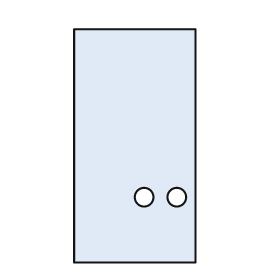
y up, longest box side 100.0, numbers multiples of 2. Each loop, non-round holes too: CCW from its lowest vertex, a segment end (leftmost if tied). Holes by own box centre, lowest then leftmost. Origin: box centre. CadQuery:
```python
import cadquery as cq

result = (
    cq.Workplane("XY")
    .moveTo(-26.0, -50.0)
    .lineTo(26.0, -50.0)
    .lineTo(26.0, 50.0)
    .lineTo(-26.0, 50.0)
    .close()
    .moveTo(4.0, -22.0)
    .circle(4.0)
    .moveTo(18.0, -22.0)
    .circle(4.0)
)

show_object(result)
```